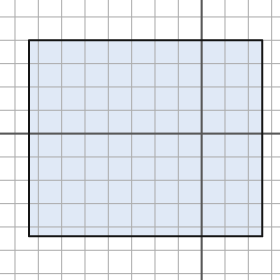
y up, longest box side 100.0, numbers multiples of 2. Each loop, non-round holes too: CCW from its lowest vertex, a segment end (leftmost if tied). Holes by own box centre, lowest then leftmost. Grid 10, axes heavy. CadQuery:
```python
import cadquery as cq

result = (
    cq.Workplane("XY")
    .moveTo(-74.0, -44.0)
    .lineTo(26.0, -44.0)
    .lineTo(26.0, 40.0)
    .lineTo(-74.0, 40.0)
    .close()
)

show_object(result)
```